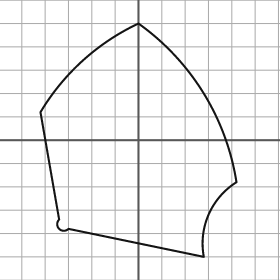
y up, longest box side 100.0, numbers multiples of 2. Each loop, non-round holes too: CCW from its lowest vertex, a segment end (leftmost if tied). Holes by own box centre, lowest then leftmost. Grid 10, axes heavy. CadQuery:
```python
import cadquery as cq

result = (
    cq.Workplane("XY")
    .moveTo(28.0, -50.0)
    .threePointArc((30.0, -32.0), (42.0, -18.0))
    .threePointArc((28.0, 20.0), (0.0, 50.0))
    .threePointArc((-24.0, 34.0), (-42.0, 12.0))
    .lineTo(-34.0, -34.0)
    .threePointArc((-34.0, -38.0), (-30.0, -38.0))
    .close()
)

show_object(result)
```